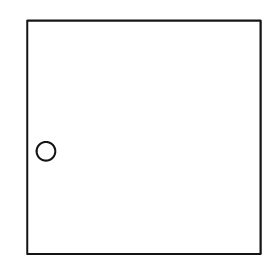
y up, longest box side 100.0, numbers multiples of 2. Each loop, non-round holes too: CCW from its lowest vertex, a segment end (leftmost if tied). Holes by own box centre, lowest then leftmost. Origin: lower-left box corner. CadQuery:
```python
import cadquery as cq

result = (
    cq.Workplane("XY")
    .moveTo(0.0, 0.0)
    .lineTo(100.0, 0.0)
    .lineTo(100.0, 100.0)
    .lineTo(0.0, 100.0)
    .close()
    .moveTo(8.0, 44.0)
    .circle(4.0)
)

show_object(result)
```